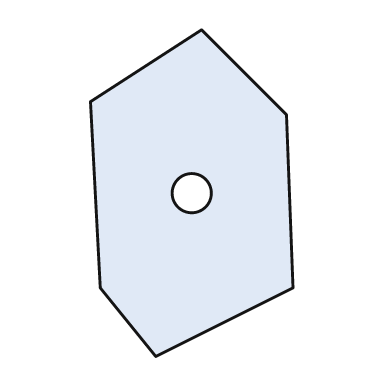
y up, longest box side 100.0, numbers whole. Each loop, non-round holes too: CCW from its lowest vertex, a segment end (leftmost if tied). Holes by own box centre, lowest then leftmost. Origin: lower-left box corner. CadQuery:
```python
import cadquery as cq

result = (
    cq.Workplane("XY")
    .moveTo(20.0, 0.0)
    .lineTo(62.0, 21.0)
    .lineTo(60.0, 74.0)
    .lineTo(34.0, 100.0)
    .lineTo(0.0, 78.0)
    .lineTo(3.0, 21.0)
    .close()
    .moveTo(31.0, 50.0)
    .circle(6.0)
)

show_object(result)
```